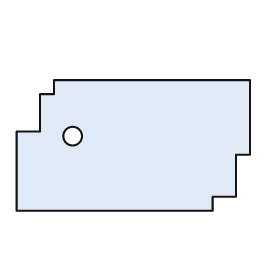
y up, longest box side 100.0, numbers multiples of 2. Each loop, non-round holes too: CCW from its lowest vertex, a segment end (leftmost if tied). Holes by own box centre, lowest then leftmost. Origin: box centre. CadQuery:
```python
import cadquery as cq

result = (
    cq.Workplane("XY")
    .moveTo(-50.0, -28.0)
    .lineTo(34.0, -28.0)
    .lineTo(34.0, -22.0)
    .lineTo(44.0, -22.0)
    .lineTo(44.0, -4.0)
    .lineTo(50.0, -4.0)
    .lineTo(50.0, 28.0)
    .lineTo(-34.0, 28.0)
    .lineTo(-34.0, 22.0)
    .lineTo(-40.0, 22.0)
    .lineTo(-40.0, 6.0)
    .lineTo(-50.0, 6.0)
    .close()
    .moveTo(-26.0, 4.0)
    .circle(4.0)
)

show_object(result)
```